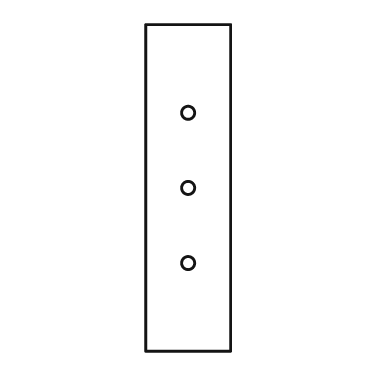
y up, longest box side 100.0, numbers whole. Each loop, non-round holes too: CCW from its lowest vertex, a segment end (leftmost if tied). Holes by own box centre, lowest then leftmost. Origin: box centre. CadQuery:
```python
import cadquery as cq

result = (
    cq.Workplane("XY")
    .moveTo(-13.0, -50.0)
    .lineTo(13.0, -50.0)
    .lineTo(13.0, 50.0)
    .lineTo(-13.0, 50.0)
    .close()
    .moveTo(0.0, -23.0)
    .circle(2.0)
    .moveTo(0.0, 0.0)
    .circle(2.0)
    .moveTo(0.0, 23.0)
    .circle(2.0)
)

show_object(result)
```